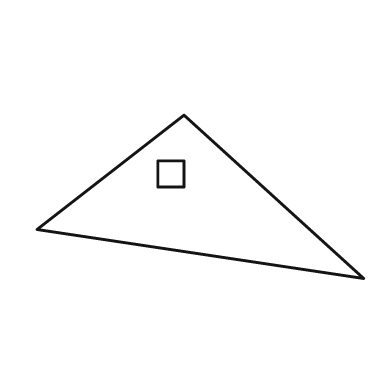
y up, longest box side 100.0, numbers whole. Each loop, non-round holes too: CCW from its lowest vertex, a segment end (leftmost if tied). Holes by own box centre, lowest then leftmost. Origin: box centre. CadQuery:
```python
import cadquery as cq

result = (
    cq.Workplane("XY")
    .moveTo(50.0, -25.0)
    .lineTo(-5.0, 25.0)
    .lineTo(-50.0, -10.0)
    .close()
    .moveTo(-13.0, 3.0)
    .lineTo(-5.0, 3.0)
    .lineTo(-5.0, 11.0)
    .lineTo(-13.0, 11.0)
    .close()
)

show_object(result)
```